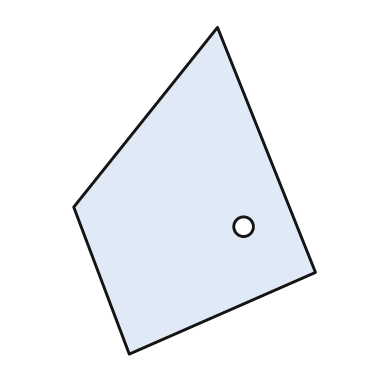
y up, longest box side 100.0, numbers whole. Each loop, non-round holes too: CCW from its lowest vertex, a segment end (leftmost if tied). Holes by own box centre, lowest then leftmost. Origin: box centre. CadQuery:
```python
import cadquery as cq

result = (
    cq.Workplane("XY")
    .moveTo(-20.0, -50.0)
    .lineTo(37.0, -25.0)
    .lineTo(7.0, 50.0)
    .lineTo(-37.0, -5.0)
    .close()
    .moveTo(15.0, -11.0)
    .circle(3.0)
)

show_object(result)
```